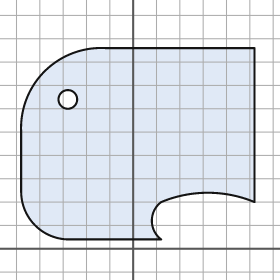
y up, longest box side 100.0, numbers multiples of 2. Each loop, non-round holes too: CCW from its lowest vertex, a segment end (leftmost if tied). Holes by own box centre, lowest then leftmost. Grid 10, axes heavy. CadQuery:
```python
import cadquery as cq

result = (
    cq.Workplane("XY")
    .moveTo(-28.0, 4.0)
    .lineTo(12.0, 4.0)
    .threePointArc((8.0, 12.0), (12.0, 20.0))
    .threePointArc((32.0, 24.0), (52.0, 20.0))
    .lineTo(52.0, 86.0)
    .lineTo(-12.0, 86.0)
    .threePointArc((-38.0, 76.0), (-48.0, 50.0))
    .lineTo(-48.0, 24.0)
    .threePointArc((-42.0, 10.0), (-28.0, 4.0))
    .close()
    .moveTo(-28.0, 64.0)
    .circle(4.0)
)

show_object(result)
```